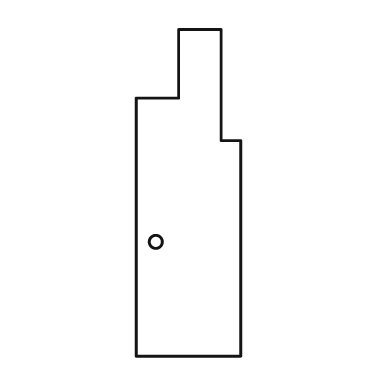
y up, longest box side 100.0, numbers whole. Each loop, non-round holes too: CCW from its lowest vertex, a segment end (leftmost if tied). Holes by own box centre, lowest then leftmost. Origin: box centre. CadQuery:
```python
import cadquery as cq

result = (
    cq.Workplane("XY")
    .moveTo(-16.0, -50.0)
    .lineTo(16.0, -50.0)
    .lineTo(16.0, 16.0)
    .lineTo(10.0, 16.0)
    .lineTo(10.0, 50.0)
    .lineTo(-3.0, 50.0)
    .lineTo(-3.0, 29.0)
    .lineTo(-16.0, 29.0)
    .close()
    .moveTo(-10.0, -15.0)
    .circle(2.0)
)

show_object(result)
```